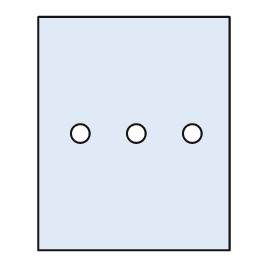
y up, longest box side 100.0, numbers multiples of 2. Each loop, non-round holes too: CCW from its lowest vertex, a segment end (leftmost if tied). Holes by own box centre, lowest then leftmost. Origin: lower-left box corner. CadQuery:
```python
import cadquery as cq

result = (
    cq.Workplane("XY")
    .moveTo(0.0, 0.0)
    .lineTo(82.0, 0.0)
    .lineTo(82.0, 100.0)
    .lineTo(0.0, 100.0)
    .close()
    .moveTo(18.0, 50.0)
    .circle(4.0)
    .moveTo(42.0, 50.0)
    .circle(4.0)
    .moveTo(66.0, 50.0)
    .circle(4.0)
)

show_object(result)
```